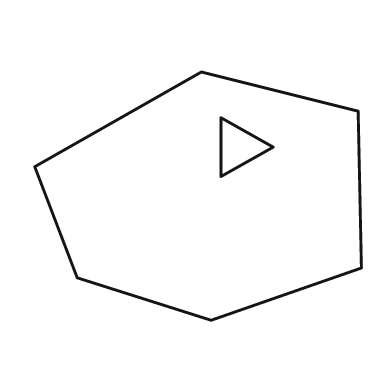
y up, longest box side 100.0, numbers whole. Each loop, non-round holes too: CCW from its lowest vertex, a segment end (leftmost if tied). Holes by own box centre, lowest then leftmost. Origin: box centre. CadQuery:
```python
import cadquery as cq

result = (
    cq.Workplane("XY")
    .moveTo(4.0, -38.0)
    .lineTo(50.0, -22.0)
    .lineTo(49.0, 26.0)
    .lineTo(1.0, 38.0)
    .lineTo(-50.0, 9.0)
    .lineTo(-37.0, -25.0)
    .close()
    .moveTo(7.0, 6.0)
    .lineTo(23.0, 15.0)
    .lineTo(7.0, 24.0)
    .close()
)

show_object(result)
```